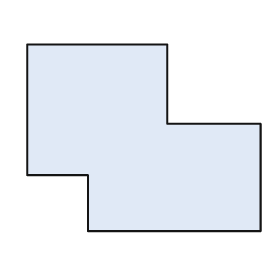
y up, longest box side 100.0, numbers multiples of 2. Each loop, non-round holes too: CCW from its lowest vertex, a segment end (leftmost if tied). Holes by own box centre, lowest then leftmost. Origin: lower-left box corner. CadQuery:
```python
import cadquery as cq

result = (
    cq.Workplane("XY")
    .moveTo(26.0, 0.0)
    .lineTo(100.0, 0.0)
    .lineTo(100.0, 46.0)
    .lineTo(60.0, 46.0)
    .lineTo(60.0, 80.0)
    .lineTo(0.0, 80.0)
    .lineTo(0.0, 24.0)
    .lineTo(26.0, 24.0)
    .close()
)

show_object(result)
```